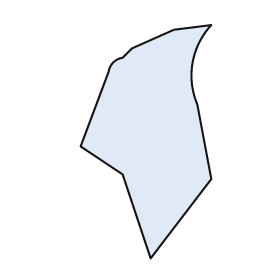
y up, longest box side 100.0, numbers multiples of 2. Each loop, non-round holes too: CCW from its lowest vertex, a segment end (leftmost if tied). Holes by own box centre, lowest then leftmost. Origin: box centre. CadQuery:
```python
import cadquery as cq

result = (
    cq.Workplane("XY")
    .moveTo(2.0, -50.0)
    .lineTo(28.0, -16.0)
    .lineTo(22.0, 16.0)
    .threePointArc((20.0, 34.0), (28.0, 50.0))
    .lineTo(12.0, 48.0)
    .lineTo(-6.0, 40.0)
    .lineTo(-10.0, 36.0)
    .threePointArc((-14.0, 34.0), (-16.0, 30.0))
    .lineTo(-28.0, -2.0)
    .lineTo(-10.0, -14.0)
    .close()
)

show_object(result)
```